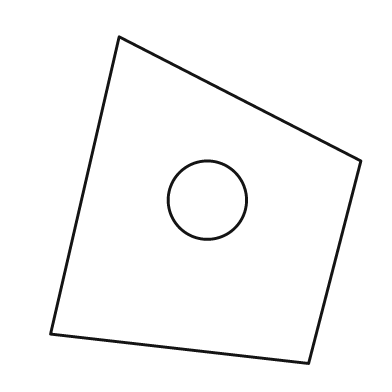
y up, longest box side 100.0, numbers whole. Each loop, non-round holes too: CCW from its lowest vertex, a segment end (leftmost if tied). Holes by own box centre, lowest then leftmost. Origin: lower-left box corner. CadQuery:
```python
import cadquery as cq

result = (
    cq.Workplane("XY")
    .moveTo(79.0, 0.0)
    .lineTo(95.0, 62.0)
    .lineTo(21.0, 100.0)
    .lineTo(0.0, 9.0)
    .close()
    .moveTo(48.0, 50.0)
    .circle(12.0)
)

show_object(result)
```